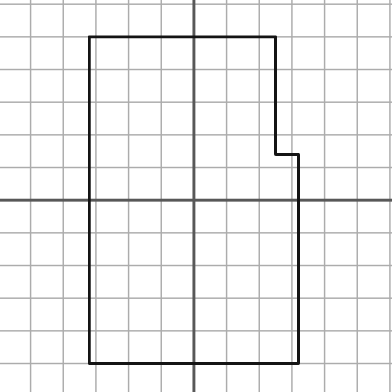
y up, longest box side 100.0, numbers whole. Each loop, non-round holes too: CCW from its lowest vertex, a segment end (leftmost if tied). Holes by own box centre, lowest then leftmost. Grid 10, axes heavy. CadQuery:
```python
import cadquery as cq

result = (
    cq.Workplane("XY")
    .moveTo(-32.0, -50.0)
    .lineTo(32.0, -50.0)
    .lineTo(32.0, 14.0)
    .lineTo(25.0, 14.0)
    .lineTo(25.0, 50.0)
    .lineTo(-32.0, 50.0)
    .close()
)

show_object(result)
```